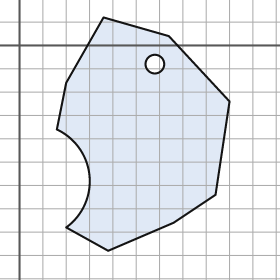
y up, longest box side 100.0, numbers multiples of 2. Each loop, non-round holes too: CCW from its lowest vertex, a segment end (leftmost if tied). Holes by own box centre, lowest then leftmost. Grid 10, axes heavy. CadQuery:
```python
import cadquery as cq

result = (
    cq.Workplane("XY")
    .moveTo(38.0, -88.0)
    .lineTo(66.0, -76.0)
    .lineTo(84.0, -64.0)
    .lineTo(90.0, -24.0)
    .lineTo(64.0, 4.0)
    .lineTo(36.0, 12.0)
    .lineTo(20.0, -16.0)
    .lineTo(16.0, -36.0)
    .threePointArc((30.0, -56.0), (20.0, -78.0))
    .close()
    .moveTo(58.0, -8.0)
    .circle(4.0)
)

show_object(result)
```